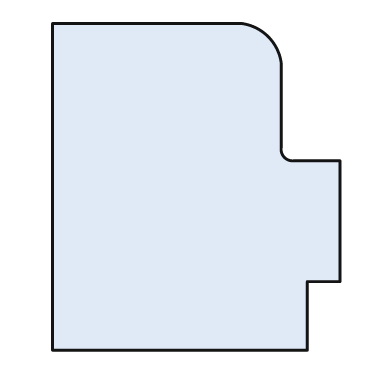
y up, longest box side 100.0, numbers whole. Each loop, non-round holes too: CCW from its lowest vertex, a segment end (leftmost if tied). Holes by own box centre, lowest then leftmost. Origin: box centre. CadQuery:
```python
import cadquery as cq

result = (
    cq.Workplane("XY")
    .moveTo(-44.0, -50.0)
    .lineTo(34.0, -50.0)
    .lineTo(34.0, -29.0)
    .lineTo(44.0, -29.0)
    .lineTo(44.0, 8.0)
    .lineTo(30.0, 8.0)
    .threePointArc((27.0, 9.0), (26.0, 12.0))
    .lineTo(26.0, 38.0)
    .threePointArc((22.0, 46.0), (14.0, 50.0))
    .lineTo(-44.0, 50.0)
    .close()
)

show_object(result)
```